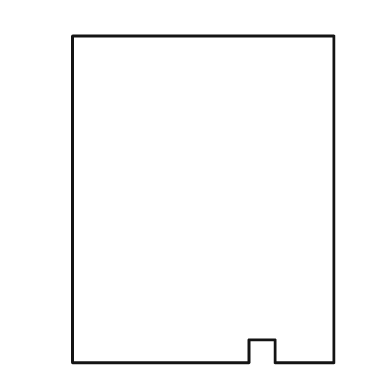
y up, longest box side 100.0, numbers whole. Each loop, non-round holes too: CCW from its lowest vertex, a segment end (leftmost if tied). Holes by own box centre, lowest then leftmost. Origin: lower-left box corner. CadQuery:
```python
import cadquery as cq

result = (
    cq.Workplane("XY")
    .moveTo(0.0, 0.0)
    .lineTo(54.0, 0.0)
    .lineTo(54.0, 7.0)
    .lineTo(62.0, 7.0)
    .lineTo(62.0, 0.0)
    .lineTo(80.0, 0.0)
    .lineTo(80.0, 100.0)
    .lineTo(0.0, 100.0)
    .close()
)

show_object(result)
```